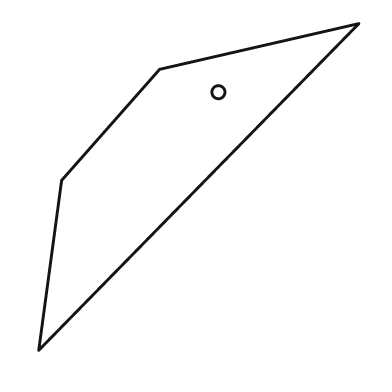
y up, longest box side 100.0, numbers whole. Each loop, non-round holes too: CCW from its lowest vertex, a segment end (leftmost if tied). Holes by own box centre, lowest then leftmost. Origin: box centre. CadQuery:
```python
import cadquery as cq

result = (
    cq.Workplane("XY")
    .moveTo(-49.0, -50.0)
    .lineTo(49.0, 50.0)
    .lineTo(-12.0, 36.0)
    .lineTo(-42.0, 2.0)
    .close()
    .moveTo(6.0, 29.0)
    .circle(2.0)
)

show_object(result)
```